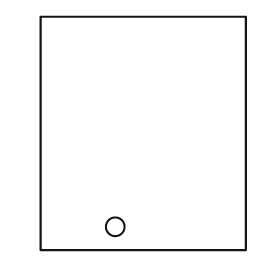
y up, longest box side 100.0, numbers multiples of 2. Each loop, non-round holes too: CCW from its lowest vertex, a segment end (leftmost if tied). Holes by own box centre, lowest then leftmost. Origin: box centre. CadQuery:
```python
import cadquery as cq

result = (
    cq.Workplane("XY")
    .moveTo(-44.0, -50.0)
    .lineTo(44.0, -50.0)
    .lineTo(44.0, 50.0)
    .lineTo(-44.0, 50.0)
    .close()
    .moveTo(-12.0, -40.0)
    .circle(4.0)
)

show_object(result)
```